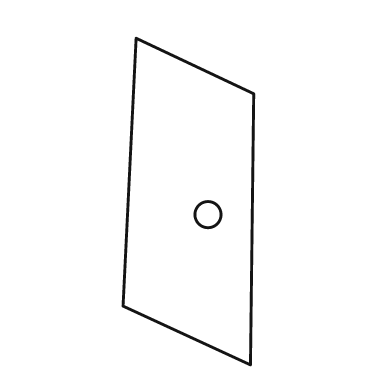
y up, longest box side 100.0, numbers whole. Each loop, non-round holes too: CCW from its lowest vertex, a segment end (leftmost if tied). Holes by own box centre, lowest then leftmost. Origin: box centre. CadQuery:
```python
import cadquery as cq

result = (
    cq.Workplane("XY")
    .moveTo(19.0, -50.0)
    .lineTo(20.0, 33.0)
    .lineTo(-16.0, 50.0)
    .lineTo(-20.0, -32.0)
    .close()
    .moveTo(6.0, -4.0)
    .circle(4.0)
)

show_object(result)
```